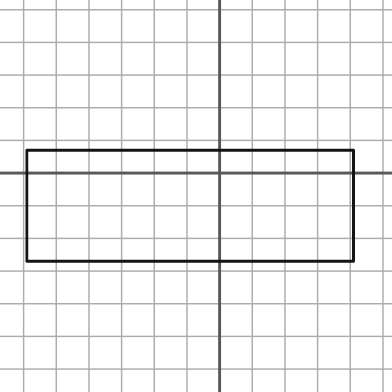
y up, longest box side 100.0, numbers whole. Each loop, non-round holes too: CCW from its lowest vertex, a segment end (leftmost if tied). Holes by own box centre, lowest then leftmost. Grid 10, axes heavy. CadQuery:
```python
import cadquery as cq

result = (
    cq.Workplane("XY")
    .moveTo(-59.0, -27.0)
    .lineTo(41.0, -27.0)
    .lineTo(41.0, 7.0)
    .lineTo(-59.0, 7.0)
    .close()
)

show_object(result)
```